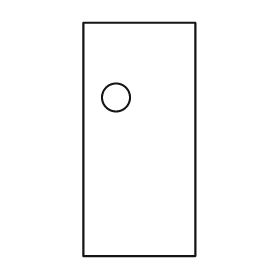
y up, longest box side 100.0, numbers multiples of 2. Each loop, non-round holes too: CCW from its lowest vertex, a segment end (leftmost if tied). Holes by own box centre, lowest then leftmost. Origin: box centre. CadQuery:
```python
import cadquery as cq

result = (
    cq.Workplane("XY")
    .moveTo(-24.0, -50.0)
    .lineTo(24.0, -50.0)
    .lineTo(24.0, 50.0)
    .lineTo(-24.0, 50.0)
    .close()
    .moveTo(-10.0, 18.0)
    .circle(6.0)
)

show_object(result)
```